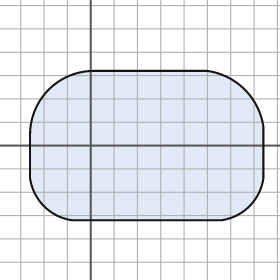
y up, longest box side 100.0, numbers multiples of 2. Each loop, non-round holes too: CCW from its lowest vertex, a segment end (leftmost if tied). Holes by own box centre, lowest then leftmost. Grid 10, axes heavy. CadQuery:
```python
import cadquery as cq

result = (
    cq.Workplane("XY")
    .moveTo(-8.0, -32.0)
    .lineTo(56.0, -32.0)
    .threePointArc((68.0, -26.0), (74.0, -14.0))
    .lineTo(74.0, 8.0)
    .threePointArc((66.0, 24.0), (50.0, 32.0))
    .lineTo(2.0, 32.0)
    .threePointArc((-18.0, 24.0), (-26.0, 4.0))
    .lineTo(-26.0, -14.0)
    .threePointArc((-20.0, -26.0), (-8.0, -32.0))
    .close()
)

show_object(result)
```